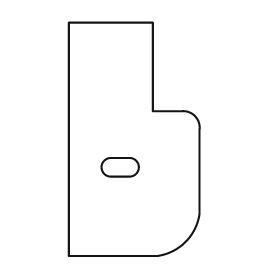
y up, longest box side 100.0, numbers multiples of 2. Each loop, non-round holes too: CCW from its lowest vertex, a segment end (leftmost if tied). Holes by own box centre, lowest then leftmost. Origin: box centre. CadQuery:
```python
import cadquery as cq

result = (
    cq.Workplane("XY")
    .moveTo(-28.0, -50.0)
    .lineTo(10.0, -50.0)
    .threePointArc((22.0, -44.0), (28.0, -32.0))
    .lineTo(28.0, 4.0)
    .threePointArc((26.0, 10.0), (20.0, 12.0))
    .lineTo(8.0, 12.0)
    .lineTo(8.0, 50.0)
    .lineTo(-28.0, 50.0)
    .close()
    .moveTo(-10.0, -16.0)
    .lineTo(-2.0, -16.0)
    .threePointArc((2.0, -12.0), (-2.0, -8.0))
    .lineTo(-10.0, -8.0)
    .threePointArc((-14.0, -12.0), (-10.0, -16.0))
    .close()
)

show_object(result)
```